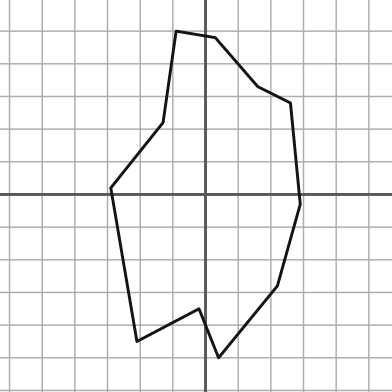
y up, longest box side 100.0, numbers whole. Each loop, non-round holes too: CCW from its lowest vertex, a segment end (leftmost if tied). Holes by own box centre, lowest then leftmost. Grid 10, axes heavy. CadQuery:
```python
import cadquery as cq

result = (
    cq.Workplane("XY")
    .moveTo(4.0, -50.0)
    .lineTo(22.0, -28.0)
    .lineTo(29.0, -3.0)
    .lineTo(26.0, 28.0)
    .lineTo(16.0, 33.0)
    .lineTo(3.0, 48.0)
    .lineTo(-9.0, 50.0)
    .lineTo(-13.0, 22.0)
    .lineTo(-29.0, 2.0)
    .lineTo(-21.0, -45.0)
    .lineTo(-2.0, -35.0)
    .close()
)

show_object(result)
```